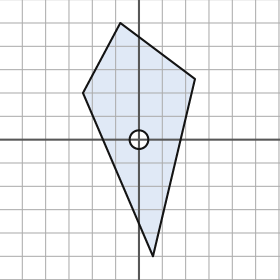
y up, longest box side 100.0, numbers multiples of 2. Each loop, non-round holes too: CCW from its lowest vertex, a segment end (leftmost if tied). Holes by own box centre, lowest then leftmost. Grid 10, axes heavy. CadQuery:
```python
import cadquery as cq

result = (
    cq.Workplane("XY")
    .moveTo(6.0, -50.0)
    .lineTo(24.0, 26.0)
    .lineTo(-8.0, 50.0)
    .lineTo(-24.0, 20.0)
    .close()
    .moveTo(0.0, 0.0)
    .circle(4.0)
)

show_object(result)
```